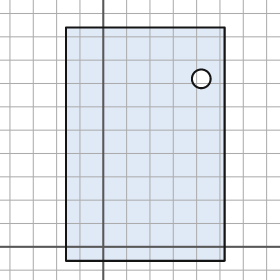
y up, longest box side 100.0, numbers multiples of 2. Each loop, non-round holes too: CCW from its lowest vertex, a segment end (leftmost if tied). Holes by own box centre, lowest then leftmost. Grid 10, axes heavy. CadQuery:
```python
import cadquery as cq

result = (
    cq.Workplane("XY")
    .moveTo(-16.0, -6.0)
    .lineTo(52.0, -6.0)
    .lineTo(52.0, 94.0)
    .lineTo(-16.0, 94.0)
    .close()
    .moveTo(42.0, 72.0)
    .circle(4.0)
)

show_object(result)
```